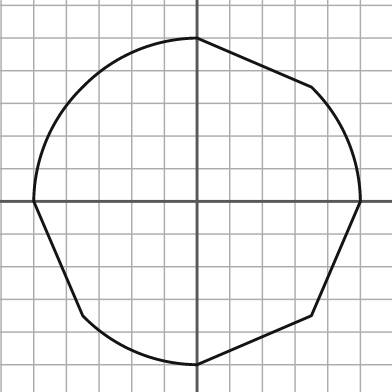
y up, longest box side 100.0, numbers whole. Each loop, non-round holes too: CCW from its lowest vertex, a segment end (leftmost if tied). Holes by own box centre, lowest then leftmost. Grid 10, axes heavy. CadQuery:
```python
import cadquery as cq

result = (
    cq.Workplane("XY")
    .moveTo(0.0, -50.0)
    .lineTo(35.0, -35.0)
    .lineTo(50.0, 0.0)
    .threePointArc((46.0, 19.0), (35.0, 35.0))
    .lineTo(0.0, 50.0)
    .threePointArc((-19.0, 46.0), (-35.0, 35.0))
    .threePointArc((-46.0, 19.0), (-50.0, 0.0))
    .lineTo(-35.0, -35.0)
    .threePointArc((-19.0, -46.0), (0.0, -50.0))
    .close()
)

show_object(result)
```